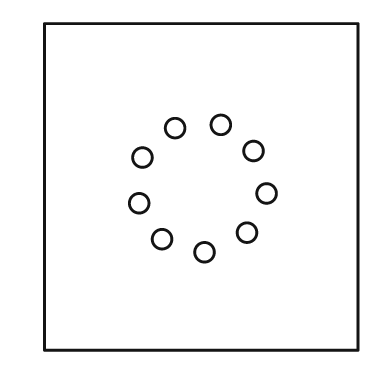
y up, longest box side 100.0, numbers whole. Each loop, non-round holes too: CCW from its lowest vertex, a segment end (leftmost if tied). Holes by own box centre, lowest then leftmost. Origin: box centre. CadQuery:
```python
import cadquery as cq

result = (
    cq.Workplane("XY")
    .moveTo(-48.0, -50.0)
    .lineTo(48.0, -50.0)
    .lineTo(48.0, 50.0)
    .lineTo(-48.0, 50.0)
    .close()
    .moveTo(1.0, -20.0)
    .circle(3.0)
    .moveTo(-12.0, -16.0)
    .circle(3.0)
    .moveTo(14.0, -14.0)
    .circle(3.0)
    .moveTo(-19.0, -5.0)
    .circle(3.0)
    .moveTo(20.0, -2.0)
    .circle(3.0)
    .moveTo(-18.0, 9.0)
    .circle(3.0)
    .moveTo(16.0, 11.0)
    .circle(3.0)
    .moveTo(-8.0, 18.0)
    .circle(3.0)
    .moveTo(6.0, 19.0)
    .circle(3.0)
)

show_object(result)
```